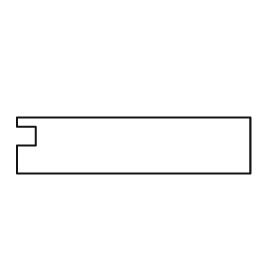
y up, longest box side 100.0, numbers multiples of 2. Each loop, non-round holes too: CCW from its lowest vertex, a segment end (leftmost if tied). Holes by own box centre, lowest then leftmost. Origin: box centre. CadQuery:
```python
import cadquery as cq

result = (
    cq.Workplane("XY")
    .moveTo(-50.0, -12.0)
    .lineTo(50.0, -12.0)
    .lineTo(50.0, 12.0)
    .lineTo(-50.0, 12.0)
    .lineTo(-50.0, 8.0)
    .lineTo(-42.0, 8.0)
    .lineTo(-42.0, 0.0)
    .lineTo(-50.0, 0.0)
    .close()
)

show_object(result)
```